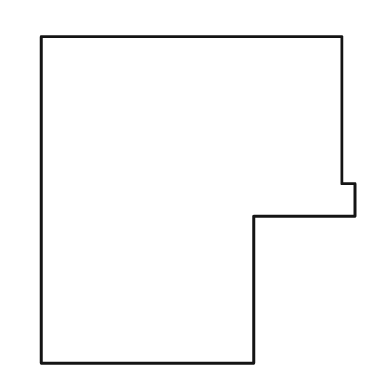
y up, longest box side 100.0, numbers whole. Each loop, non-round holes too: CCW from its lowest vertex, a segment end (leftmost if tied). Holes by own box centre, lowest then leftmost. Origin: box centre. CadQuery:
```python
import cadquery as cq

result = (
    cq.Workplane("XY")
    .moveTo(-48.0, -50.0)
    .lineTo(17.0, -50.0)
    .lineTo(17.0, -5.0)
    .lineTo(48.0, -5.0)
    .lineTo(48.0, 5.0)
    .lineTo(44.0, 5.0)
    .lineTo(44.0, 50.0)
    .lineTo(-48.0, 50.0)
    .close()
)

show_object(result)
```